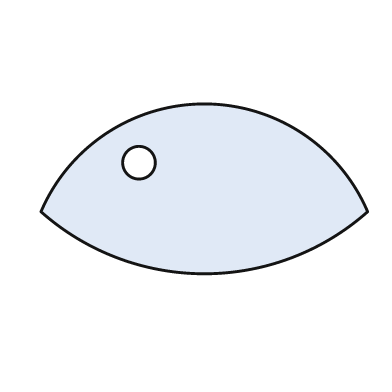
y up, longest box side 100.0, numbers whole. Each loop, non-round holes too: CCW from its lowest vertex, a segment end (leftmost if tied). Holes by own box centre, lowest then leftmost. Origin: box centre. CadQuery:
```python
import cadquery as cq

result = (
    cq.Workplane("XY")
    .moveTo(-50.0, -7.0)
    .threePointArc((0.0, -26.0), (50.0, -7.0))
    .threePointArc((0.0, 26.0), (-50.0, -7.0))
    .close()
    .moveTo(-20.0, 8.0)
    .circle(5.0)
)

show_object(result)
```